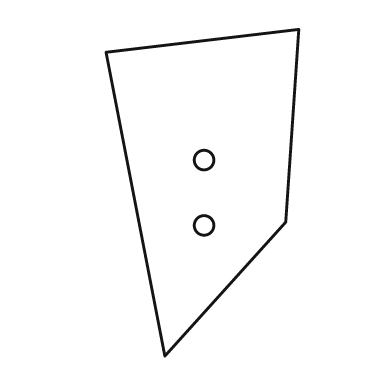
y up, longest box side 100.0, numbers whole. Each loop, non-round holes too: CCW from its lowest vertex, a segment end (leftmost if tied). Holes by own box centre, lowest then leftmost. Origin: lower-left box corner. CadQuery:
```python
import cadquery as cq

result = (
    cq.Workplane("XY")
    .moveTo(18.0, 0.0)
    .lineTo(55.0, 41.0)
    .lineTo(59.0, 100.0)
    .lineTo(0.0, 93.0)
    .close()
    .moveTo(30.0, 40.0)
    .circle(3.0)
    .moveTo(30.0, 60.0)
    .circle(3.0)
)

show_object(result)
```